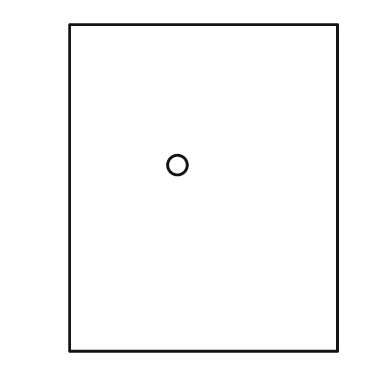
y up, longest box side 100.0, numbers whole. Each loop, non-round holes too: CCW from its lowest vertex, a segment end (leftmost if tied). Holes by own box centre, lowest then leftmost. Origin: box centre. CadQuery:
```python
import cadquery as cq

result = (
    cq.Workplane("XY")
    .moveTo(-41.0, -50.0)
    .lineTo(41.0, -50.0)
    .lineTo(41.0, 50.0)
    .lineTo(-41.0, 50.0)
    .close()
    .moveTo(-8.0, 7.0)
    .circle(3.0)
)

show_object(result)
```